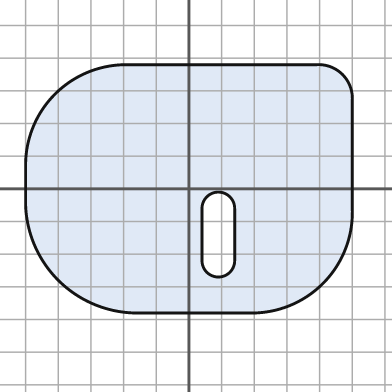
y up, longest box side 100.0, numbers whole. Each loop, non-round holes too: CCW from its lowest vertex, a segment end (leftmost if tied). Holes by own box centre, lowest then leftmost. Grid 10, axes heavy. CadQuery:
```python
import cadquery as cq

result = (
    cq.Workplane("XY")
    .moveTo(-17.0, -38.0)
    .lineTo(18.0, -38.0)
    .threePointArc((41.0, -29.0), (50.0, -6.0))
    .lineTo(50.0, 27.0)
    .threePointArc((47.0, 35.0), (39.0, 38.0))
    .lineTo(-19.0, 38.0)
    .threePointArc((-41.0, 29.0), (-50.0, 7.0))
    .lineTo(-50.0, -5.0)
    .threePointArc((-40.0, -28.0), (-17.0, -38.0))
    .close()
    .moveTo(4.0, -22.0)
    .threePointArc((9.0, -27.0), (14.0, -22.0))
    .lineTo(14.0, -6.0)
    .threePointArc((9.0, -1.0), (4.0, -6.0))
    .close()
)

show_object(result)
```